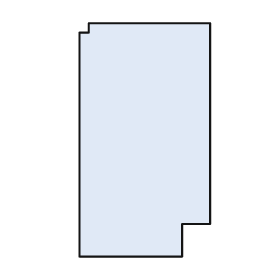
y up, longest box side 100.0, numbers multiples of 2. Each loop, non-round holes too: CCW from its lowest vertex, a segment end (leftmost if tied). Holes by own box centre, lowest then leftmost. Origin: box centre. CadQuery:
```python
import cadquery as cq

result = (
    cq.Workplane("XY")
    .moveTo(-28.0, -50.0)
    .lineTo(16.0, -50.0)
    .lineTo(16.0, -36.0)
    .lineTo(28.0, -36.0)
    .lineTo(28.0, 50.0)
    .lineTo(-24.0, 50.0)
    .lineTo(-24.0, 46.0)
    .lineTo(-28.0, 46.0)
    .close()
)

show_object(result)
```